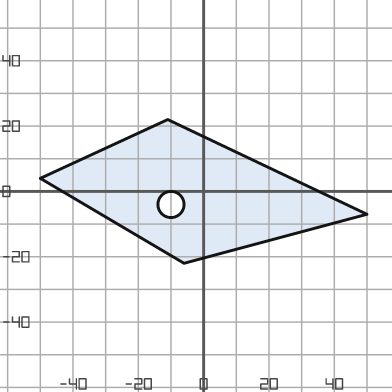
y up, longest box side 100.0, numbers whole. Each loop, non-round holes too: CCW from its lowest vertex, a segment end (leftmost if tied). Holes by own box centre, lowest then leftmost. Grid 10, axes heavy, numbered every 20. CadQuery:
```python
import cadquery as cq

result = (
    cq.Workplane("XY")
    .moveTo(-6.0, -22.0)
    .lineTo(50.0, -7.0)
    .lineTo(-11.0, 22.0)
    .lineTo(-50.0, 4.0)
    .close()
    .moveTo(-10.0, -4.0)
    .circle(4.0)
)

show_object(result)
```